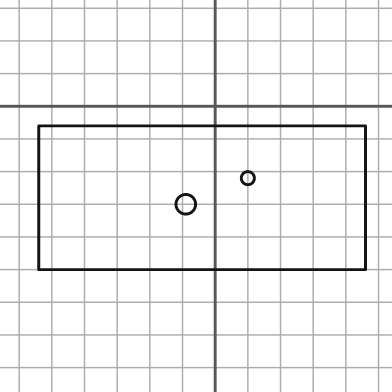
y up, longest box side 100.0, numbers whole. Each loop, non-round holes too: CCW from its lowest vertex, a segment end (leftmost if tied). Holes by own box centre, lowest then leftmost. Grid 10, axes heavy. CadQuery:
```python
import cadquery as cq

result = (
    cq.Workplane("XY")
    .moveTo(-54.0, -50.0)
    .lineTo(46.0, -50.0)
    .lineTo(46.0, -6.0)
    .lineTo(-54.0, -6.0)
    .close()
    .moveTo(-9.0, -30.0)
    .circle(3.0)
    .moveTo(10.0, -22.0)
    .circle(2.0)
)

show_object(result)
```